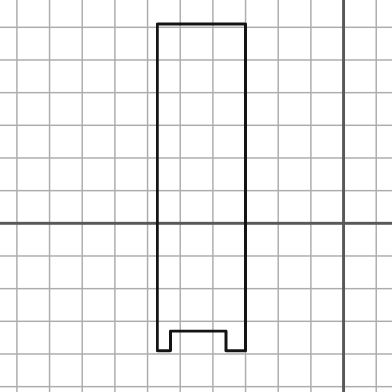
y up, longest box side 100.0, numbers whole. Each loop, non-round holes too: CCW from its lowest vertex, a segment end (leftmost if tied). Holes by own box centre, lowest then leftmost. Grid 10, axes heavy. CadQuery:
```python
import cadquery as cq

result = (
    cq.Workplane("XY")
    .moveTo(-57.0, -39.0)
    .lineTo(-53.0, -39.0)
    .lineTo(-53.0, -33.0)
    .lineTo(-36.0, -33.0)
    .lineTo(-36.0, -39.0)
    .lineTo(-30.0, -39.0)
    .lineTo(-30.0, 61.0)
    .lineTo(-57.0, 61.0)
    .close()
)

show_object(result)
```